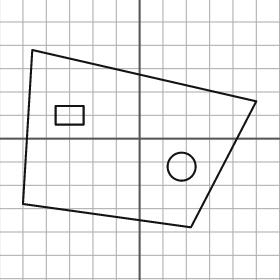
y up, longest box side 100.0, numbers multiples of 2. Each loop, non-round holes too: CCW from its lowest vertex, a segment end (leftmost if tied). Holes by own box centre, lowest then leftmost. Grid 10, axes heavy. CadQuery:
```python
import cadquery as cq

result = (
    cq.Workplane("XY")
    .moveTo(22.0, -38.0)
    .lineTo(50.0, 16.0)
    .lineTo(-46.0, 38.0)
    .lineTo(-50.0, -28.0)
    .close()
    .moveTo(18.0, -12.0)
    .circle(6.0)
    .moveTo(-36.0, 6.0)
    .lineTo(-24.0, 6.0)
    .lineTo(-24.0, 14.0)
    .lineTo(-36.0, 14.0)
    .close()
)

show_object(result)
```